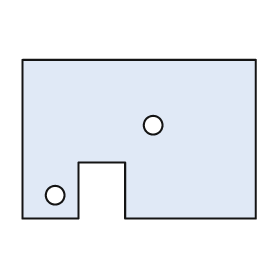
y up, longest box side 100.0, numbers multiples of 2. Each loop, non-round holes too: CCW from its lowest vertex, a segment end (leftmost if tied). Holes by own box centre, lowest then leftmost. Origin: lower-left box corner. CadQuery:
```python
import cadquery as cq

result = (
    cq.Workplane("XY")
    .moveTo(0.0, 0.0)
    .lineTo(24.0, 0.0)
    .lineTo(24.0, 24.0)
    .lineTo(44.0, 24.0)
    .lineTo(44.0, 0.0)
    .lineTo(100.0, 0.0)
    .lineTo(100.0, 68.0)
    .lineTo(0.0, 68.0)
    .close()
    .moveTo(14.0, 10.0)
    .circle(4.0)
    .moveTo(56.0, 40.0)
    .circle(4.0)
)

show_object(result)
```